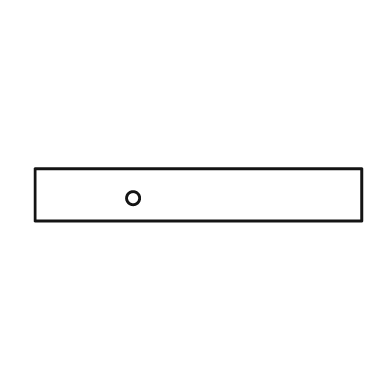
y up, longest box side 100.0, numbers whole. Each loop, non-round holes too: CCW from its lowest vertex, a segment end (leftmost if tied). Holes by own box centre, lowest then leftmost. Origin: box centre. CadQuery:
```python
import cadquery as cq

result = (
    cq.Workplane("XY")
    .moveTo(-50.0, -8.0)
    .lineTo(50.0, -8.0)
    .lineTo(50.0, 8.0)
    .lineTo(-50.0, 8.0)
    .close()
    .moveTo(-20.0, -1.0)
    .circle(2.0)
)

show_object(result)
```